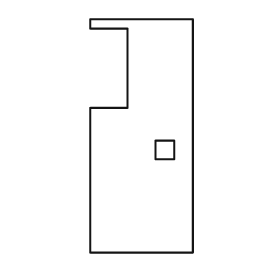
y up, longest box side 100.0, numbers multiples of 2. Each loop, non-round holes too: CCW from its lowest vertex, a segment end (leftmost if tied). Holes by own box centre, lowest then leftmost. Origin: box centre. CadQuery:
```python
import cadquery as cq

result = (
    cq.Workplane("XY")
    .moveTo(-22.0, -50.0)
    .lineTo(22.0, -50.0)
    .lineTo(22.0, 50.0)
    .lineTo(-22.0, 50.0)
    .lineTo(-22.0, 46.0)
    .lineTo(-6.0, 46.0)
    .lineTo(-6.0, 12.0)
    .lineTo(-22.0, 12.0)
    .close()
    .moveTo(6.0, -10.0)
    .lineTo(14.0, -10.0)
    .lineTo(14.0, -2.0)
    .lineTo(6.0, -2.0)
    .close()
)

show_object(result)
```